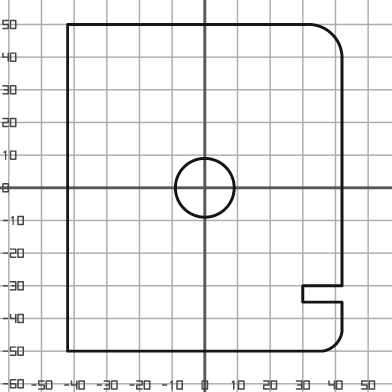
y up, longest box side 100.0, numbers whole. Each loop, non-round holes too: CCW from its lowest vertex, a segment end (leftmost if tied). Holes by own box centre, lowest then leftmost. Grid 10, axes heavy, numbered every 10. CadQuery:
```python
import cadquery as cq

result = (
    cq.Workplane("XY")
    .moveTo(-42.0, -50.0)
    .lineTo(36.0, -50.0)
    .threePointArc((40.0, -48.0), (42.0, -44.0))
    .lineTo(42.0, -35.0)
    .lineTo(30.0, -35.0)
    .lineTo(30.0, -30.0)
    .lineTo(42.0, -30.0)
    .lineTo(42.0, 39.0)
    .threePointArc((39.0, 47.0), (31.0, 50.0))
    .lineTo(-42.0, 50.0)
    .close()
    .moveTo(0.0, 0.0)
    .circle(9.0)
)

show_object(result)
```